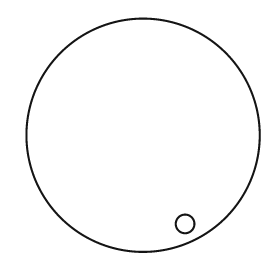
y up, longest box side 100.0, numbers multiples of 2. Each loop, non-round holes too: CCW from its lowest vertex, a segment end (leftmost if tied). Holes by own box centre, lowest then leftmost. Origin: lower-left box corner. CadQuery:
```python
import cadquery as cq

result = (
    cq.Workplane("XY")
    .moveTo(50.0, 50.0)
    .circle(50.0)
    .moveTo(68.0, 12.0)
    .circle(4.0)
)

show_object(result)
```